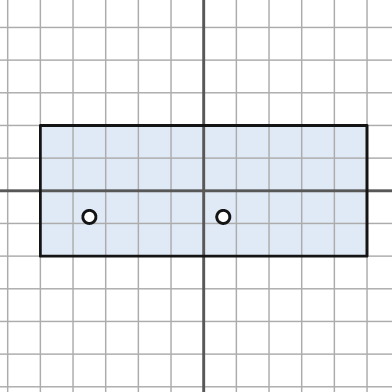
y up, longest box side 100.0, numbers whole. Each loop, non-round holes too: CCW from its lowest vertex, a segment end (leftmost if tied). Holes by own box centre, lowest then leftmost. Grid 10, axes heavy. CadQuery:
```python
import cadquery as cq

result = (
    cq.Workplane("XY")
    .moveTo(-50.0, -20.0)
    .lineTo(50.0, -20.0)
    .lineTo(50.0, 20.0)
    .lineTo(-50.0, 20.0)
    .close()
    .moveTo(-35.0, -8.0)
    .circle(2.0)
    .moveTo(6.0, -8.0)
    .circle(2.0)
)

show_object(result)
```